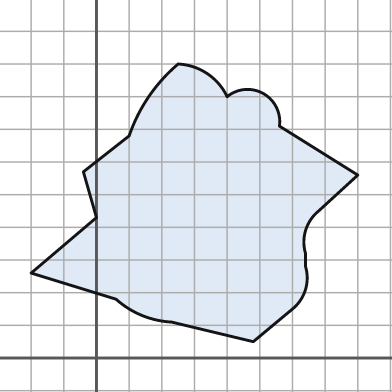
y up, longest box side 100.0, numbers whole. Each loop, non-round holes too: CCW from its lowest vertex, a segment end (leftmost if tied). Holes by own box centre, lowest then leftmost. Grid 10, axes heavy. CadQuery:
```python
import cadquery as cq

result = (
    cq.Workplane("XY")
    .moveTo(48.0, 5.0)
    .lineTo(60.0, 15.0)
    .threePointArc((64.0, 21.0), (64.0, 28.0))
    .lineTo(64.0, 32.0)
    .threePointArc((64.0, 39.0), (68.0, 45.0))
    .lineTo(80.0, 56.0)
    .lineTo(56.0, 71.0)
    .threePointArc((51.0, 81.0), (40.0, 80.0))
    .threePointArc((34.0, 87.0), (25.0, 90.0))
    .threePointArc((16.0, 80.0), (10.0, 68.0))
    .lineTo(-4.0, 57.0)
    .lineTo(0.0, 43.0)
    .lineTo(-20.0, 26.0)
    .lineTo(6.0, 18.0)
    .threePointArc((14.0, 13.0), (23.0, 11.0))
    .close()
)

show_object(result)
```